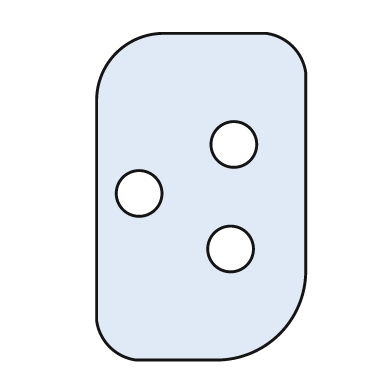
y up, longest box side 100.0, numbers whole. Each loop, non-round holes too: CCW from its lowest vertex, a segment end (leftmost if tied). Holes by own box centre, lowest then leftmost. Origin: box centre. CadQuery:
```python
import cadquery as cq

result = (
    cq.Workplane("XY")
    .moveTo(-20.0, -50.0)
    .lineTo(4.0, -50.0)
    .threePointArc((24.0, -42.0), (32.0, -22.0))
    .lineTo(32.0, 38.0)
    .threePointArc((28.0, 46.0), (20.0, 50.0))
    .lineTo(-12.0, 50.0)
    .threePointArc((-26.0, 44.0), (-32.0, 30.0))
    .lineTo(-32.0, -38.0)
    .threePointArc((-28.0, -46.0), (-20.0, -50.0))
    .close()
    .moveTo(9.0, -16.0)
    .circle(7.0)
    .moveTo(-19.0, 1.0)
    .circle(7.0)
    .moveTo(10.0, 16.0)
    .circle(7.0)
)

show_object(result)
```